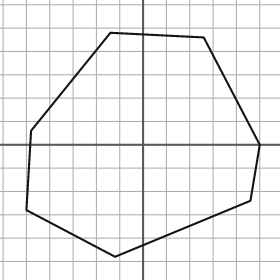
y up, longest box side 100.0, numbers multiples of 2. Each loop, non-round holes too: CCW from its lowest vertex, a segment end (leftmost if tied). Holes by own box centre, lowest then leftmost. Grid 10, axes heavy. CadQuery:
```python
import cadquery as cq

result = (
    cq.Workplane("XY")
    .moveTo(-12.0, -48.0)
    .lineTo(46.0, -24.0)
    .lineTo(50.0, 0.0)
    .lineTo(26.0, 46.0)
    .lineTo(-14.0, 48.0)
    .lineTo(-48.0, 6.0)
    .lineTo(-50.0, -28.0)
    .close()
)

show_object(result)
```